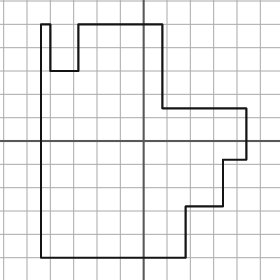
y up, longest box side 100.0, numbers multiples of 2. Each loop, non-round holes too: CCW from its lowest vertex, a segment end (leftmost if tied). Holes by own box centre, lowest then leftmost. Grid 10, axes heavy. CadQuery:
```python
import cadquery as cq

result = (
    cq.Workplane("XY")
    .moveTo(-44.0, -50.0)
    .lineTo(18.0, -50.0)
    .lineTo(18.0, -28.0)
    .lineTo(34.0, -28.0)
    .lineTo(34.0, -8.0)
    .lineTo(44.0, -8.0)
    .lineTo(44.0, 14.0)
    .lineTo(8.0, 14.0)
    .lineTo(8.0, 50.0)
    .lineTo(-28.0, 50.0)
    .lineTo(-28.0, 30.0)
    .lineTo(-40.0, 30.0)
    .lineTo(-40.0, 50.0)
    .lineTo(-44.0, 50.0)
    .close()
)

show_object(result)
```